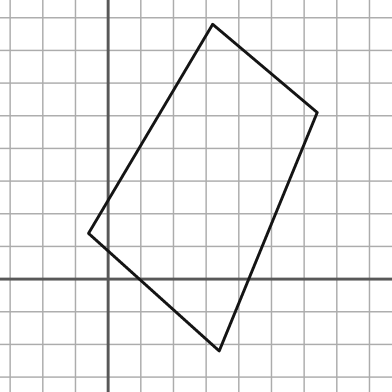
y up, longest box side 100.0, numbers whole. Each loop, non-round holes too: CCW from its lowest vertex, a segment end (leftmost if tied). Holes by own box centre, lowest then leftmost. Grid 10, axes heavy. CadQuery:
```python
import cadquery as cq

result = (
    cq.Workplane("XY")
    .moveTo(34.0, -22.0)
    .lineTo(64.0, 51.0)
    .lineTo(32.0, 78.0)
    .lineTo(-6.0, 14.0)
    .close()
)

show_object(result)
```